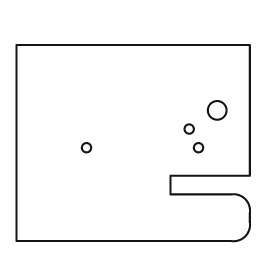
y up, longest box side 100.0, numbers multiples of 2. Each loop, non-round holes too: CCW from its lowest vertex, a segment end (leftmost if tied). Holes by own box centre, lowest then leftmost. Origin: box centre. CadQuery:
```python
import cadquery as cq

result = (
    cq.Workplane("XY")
    .moveTo(-50.0, -42.0)
    .lineTo(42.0, -42.0)
    .threePointArc((48.0, -40.0), (50.0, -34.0))
    .lineTo(50.0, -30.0)
    .threePointArc((48.0, -24.0), (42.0, -22.0))
    .lineTo(16.0, -22.0)
    .lineTo(16.0, -14.0)
    .lineTo(50.0, -14.0)
    .lineTo(50.0, 42.0)
    .lineTo(-50.0, 42.0)
    .close()
    .moveTo(-20.0, -2.0)
    .circle(2.0)
    .moveTo(28.0, -2.0)
    .circle(2.0)
    .moveTo(24.0, 6.0)
    .circle(2.0)
    .moveTo(36.0, 14.0)
    .circle(4.0)
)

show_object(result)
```